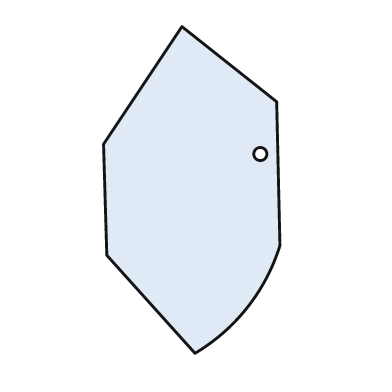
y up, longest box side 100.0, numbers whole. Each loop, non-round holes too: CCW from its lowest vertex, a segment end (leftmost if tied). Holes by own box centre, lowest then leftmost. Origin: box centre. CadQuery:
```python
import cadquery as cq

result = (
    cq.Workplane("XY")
    .moveTo(1.0, -50.0)
    .threePointArc((17.0, -36.0), (27.0, -17.0))
    .lineTo(26.0, 27.0)
    .lineTo(-3.0, 50.0)
    .lineTo(-27.0, 14.0)
    .lineTo(-26.0, -20.0)
    .close()
    .moveTo(21.0, 11.0)
    .circle(2.0)
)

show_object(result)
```